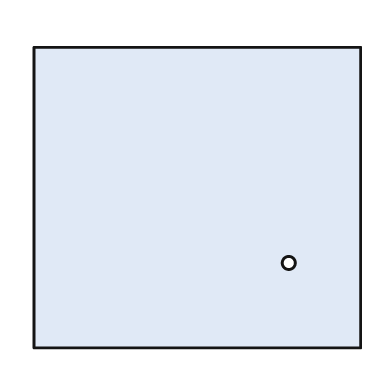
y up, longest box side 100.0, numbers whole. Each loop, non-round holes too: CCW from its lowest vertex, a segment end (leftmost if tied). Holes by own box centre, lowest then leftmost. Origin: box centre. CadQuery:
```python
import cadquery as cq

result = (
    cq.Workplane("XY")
    .moveTo(-50.0, -46.0)
    .lineTo(50.0, -46.0)
    .lineTo(50.0, 46.0)
    .lineTo(-50.0, 46.0)
    .close()
    .moveTo(28.0, -20.0)
    .circle(2.0)
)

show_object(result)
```